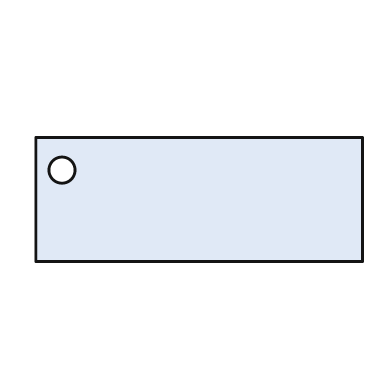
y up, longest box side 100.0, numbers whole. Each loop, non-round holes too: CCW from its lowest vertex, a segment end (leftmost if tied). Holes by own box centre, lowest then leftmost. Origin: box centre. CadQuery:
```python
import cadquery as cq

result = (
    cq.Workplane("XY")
    .moveTo(-50.0, -19.0)
    .lineTo(50.0, -19.0)
    .lineTo(50.0, 19.0)
    .lineTo(-50.0, 19.0)
    .close()
    .moveTo(-42.0, 9.0)
    .circle(4.0)
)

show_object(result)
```